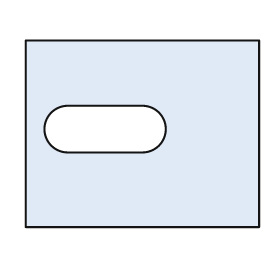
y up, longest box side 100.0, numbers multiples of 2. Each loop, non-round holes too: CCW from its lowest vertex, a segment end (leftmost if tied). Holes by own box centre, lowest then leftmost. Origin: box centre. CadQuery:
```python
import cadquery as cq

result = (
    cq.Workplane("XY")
    .moveTo(-50.0, -40.0)
    .lineTo(50.0, -40.0)
    .lineTo(50.0, 40.0)
    .lineTo(-50.0, 40.0)
    .close()
    .moveTo(-32.0, -8.0)
    .lineTo(0.0, -8.0)
    .threePointArc((10.0, 2.0), (0.0, 12.0))
    .lineTo(-32.0, 12.0)
    .threePointArc((-42.0, 2.0), (-32.0, -8.0))
    .close()
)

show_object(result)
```